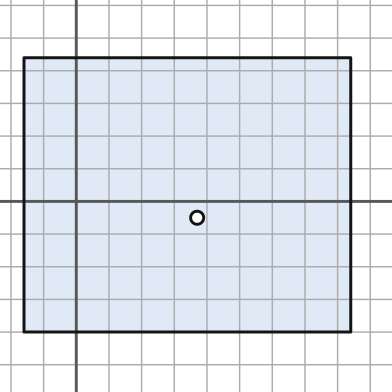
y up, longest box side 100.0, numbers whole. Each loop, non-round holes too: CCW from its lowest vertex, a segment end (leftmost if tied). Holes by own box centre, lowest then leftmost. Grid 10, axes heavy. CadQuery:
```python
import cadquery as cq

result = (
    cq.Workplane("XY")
    .moveTo(-16.0, -40.0)
    .lineTo(84.0, -40.0)
    .lineTo(84.0, 44.0)
    .lineTo(-16.0, 44.0)
    .close()
    .moveTo(37.0, -5.0)
    .circle(2.0)
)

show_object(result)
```